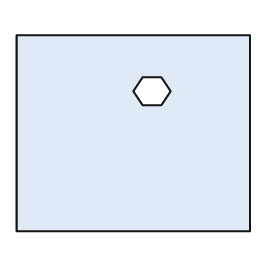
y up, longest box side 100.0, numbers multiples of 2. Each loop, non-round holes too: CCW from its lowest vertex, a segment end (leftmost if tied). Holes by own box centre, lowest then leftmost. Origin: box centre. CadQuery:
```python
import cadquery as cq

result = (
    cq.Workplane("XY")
    .moveTo(-50.0, -42.0)
    .lineTo(50.0, -42.0)
    .lineTo(50.0, 42.0)
    .lineTo(-50.0, 42.0)
    .close()
    .moveTo(4.0, 12.0)
    .lineTo(12.0, 12.0)
    .lineTo(16.0, 18.0)
    .lineTo(12.0, 24.0)
    .lineTo(4.0, 24.0)
    .lineTo(0.0, 18.0)
    .close()
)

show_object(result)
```